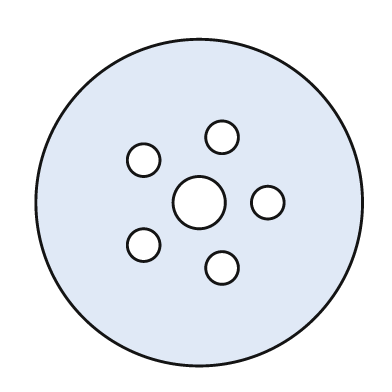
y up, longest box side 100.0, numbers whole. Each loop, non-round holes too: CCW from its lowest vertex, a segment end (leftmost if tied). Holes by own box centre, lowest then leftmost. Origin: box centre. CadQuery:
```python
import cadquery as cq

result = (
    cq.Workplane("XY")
    .moveTo(0.0, 0.0)
    .circle(50.0)
    .moveTo(7.0, -20.0)
    .circle(5.0)
    .moveTo(-17.0, -13.0)
    .circle(5.0)
    .moveTo(0.0, 0.0)
    .circle(8.0)
    .moveTo(21.0, 0.0)
    .circle(5.0)
    .moveTo(-17.0, 13.0)
    .circle(5.0)
    .moveTo(7.0, 20.0)
    .circle(5.0)
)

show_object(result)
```